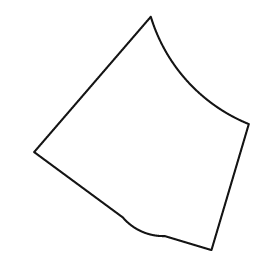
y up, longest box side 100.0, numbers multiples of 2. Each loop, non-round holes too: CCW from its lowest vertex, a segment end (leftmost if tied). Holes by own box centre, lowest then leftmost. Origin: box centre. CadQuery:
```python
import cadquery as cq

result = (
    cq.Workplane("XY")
    .moveTo(30.0, -50.0)
    .lineTo(46.0, 4.0)
    .threePointArc((20.0, 22.0), (4.0, 50.0))
    .lineTo(-46.0, -8.0)
    .lineTo(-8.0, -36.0)
    .threePointArc((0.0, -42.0), (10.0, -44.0))
    .close()
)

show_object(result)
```